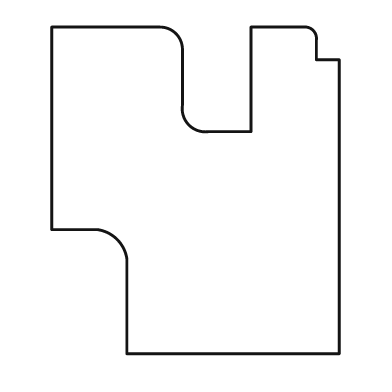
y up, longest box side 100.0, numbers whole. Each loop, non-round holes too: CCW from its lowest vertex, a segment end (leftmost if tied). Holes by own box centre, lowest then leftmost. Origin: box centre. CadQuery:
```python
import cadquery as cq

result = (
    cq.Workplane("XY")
    .moveTo(-21.0, -50.0)
    .lineTo(44.0, -50.0)
    .lineTo(44.0, 40.0)
    .lineTo(37.0, 40.0)
    .lineTo(37.0, 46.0)
    .threePointArc((36.0, 49.0), (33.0, 50.0))
    .lineTo(17.0, 50.0)
    .lineTo(17.0, 18.0)
    .lineTo(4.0, 18.0)
    .threePointArc((-2.0, 20.0), (-4.0, 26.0))
    .lineTo(-4.0, 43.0)
    .threePointArc((-6.0, 48.0), (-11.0, 50.0))
    .lineTo(-44.0, 50.0)
    .lineTo(-44.0, -12.0)
    .lineTo(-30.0, -12.0)
    .threePointArc((-24.0, -15.0), (-21.0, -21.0))
    .close()
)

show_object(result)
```